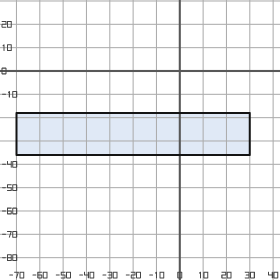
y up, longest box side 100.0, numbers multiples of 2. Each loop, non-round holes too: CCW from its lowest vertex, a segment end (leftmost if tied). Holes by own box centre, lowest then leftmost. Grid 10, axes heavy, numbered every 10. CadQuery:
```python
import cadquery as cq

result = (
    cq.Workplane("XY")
    .moveTo(-70.0, -36.0)
    .lineTo(30.0, -36.0)
    .lineTo(30.0, -18.0)
    .lineTo(-70.0, -18.0)
    .close()
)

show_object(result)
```